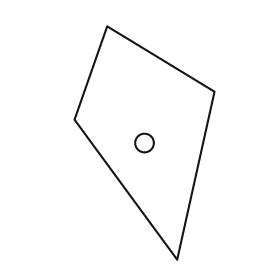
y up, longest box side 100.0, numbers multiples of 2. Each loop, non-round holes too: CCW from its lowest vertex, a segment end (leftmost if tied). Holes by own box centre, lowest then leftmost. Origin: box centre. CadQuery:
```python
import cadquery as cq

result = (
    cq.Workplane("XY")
    .moveTo(14.0, -50.0)
    .lineTo(30.0, 22.0)
    .lineTo(-16.0, 50.0)
    .lineTo(-30.0, 10.0)
    .close()
    .moveTo(0.0, 0.0)
    .circle(4.0)
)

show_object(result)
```